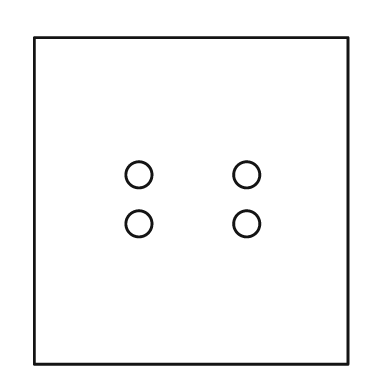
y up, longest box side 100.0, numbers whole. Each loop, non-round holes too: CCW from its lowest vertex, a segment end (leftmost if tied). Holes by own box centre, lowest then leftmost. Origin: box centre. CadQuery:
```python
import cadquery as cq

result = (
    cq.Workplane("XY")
    .moveTo(-48.0, -50.0)
    .lineTo(48.0, -50.0)
    .lineTo(48.0, 50.0)
    .lineTo(-48.0, 50.0)
    .close()
    .moveTo(-16.0, -7.0)
    .circle(4.0)
    .moveTo(17.0, -7.0)
    .circle(4.0)
    .moveTo(-16.0, 8.0)
    .circle(4.0)
    .moveTo(17.0, 8.0)
    .circle(4.0)
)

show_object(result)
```